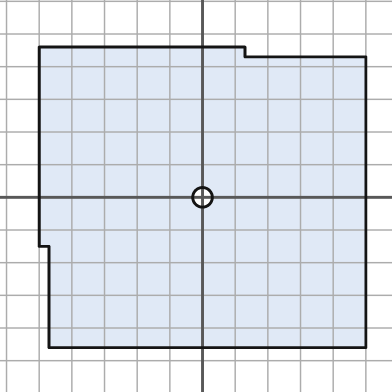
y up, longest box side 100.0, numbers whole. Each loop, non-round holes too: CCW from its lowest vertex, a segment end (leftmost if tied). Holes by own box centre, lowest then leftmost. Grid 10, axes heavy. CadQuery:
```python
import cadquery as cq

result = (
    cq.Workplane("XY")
    .moveTo(-47.0, -46.0)
    .lineTo(50.0, -46.0)
    .lineTo(50.0, 43.0)
    .lineTo(13.0, 43.0)
    .lineTo(13.0, 46.0)
    .lineTo(-50.0, 46.0)
    .lineTo(-50.0, -15.0)
    .lineTo(-47.0, -15.0)
    .close()
    .moveTo(0.0, 0.0)
    .circle(3.0)
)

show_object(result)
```